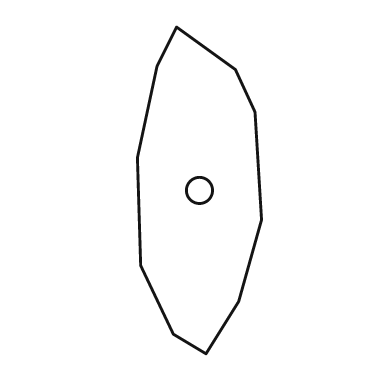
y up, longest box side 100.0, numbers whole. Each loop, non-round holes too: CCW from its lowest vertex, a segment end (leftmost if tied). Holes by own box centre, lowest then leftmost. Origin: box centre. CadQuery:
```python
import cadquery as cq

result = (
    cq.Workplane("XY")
    .moveTo(2.0, -50.0)
    .lineTo(12.0, -34.0)
    .lineTo(19.0, -9.0)
    .lineTo(17.0, 24.0)
    .lineTo(11.0, 37.0)
    .lineTo(-7.0, 50.0)
    .lineTo(-13.0, 38.0)
    .lineTo(-19.0, 10.0)
    .lineTo(-18.0, -23.0)
    .lineTo(-8.0, -44.0)
    .close()
    .moveTo(0.0, 0.0)
    .circle(4.0)
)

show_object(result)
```